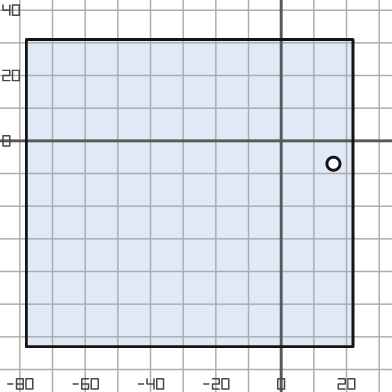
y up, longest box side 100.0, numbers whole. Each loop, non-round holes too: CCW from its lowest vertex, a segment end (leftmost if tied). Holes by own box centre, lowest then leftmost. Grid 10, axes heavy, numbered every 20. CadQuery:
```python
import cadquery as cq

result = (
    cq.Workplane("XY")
    .moveTo(-78.0, -63.0)
    .lineTo(22.0, -63.0)
    .lineTo(22.0, 31.0)
    .lineTo(-78.0, 31.0)
    .close()
    .moveTo(16.0, -7.0)
    .circle(2.0)
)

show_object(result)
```